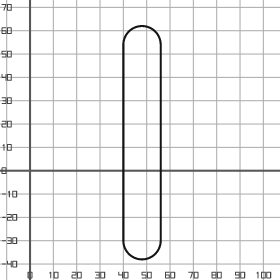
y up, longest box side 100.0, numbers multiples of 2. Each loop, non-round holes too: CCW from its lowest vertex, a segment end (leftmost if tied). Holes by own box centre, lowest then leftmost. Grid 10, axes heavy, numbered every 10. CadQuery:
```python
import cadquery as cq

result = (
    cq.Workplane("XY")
    .moveTo(40.0, -30.0)
    .threePointArc((48.0, -38.0), (56.0, -30.0))
    .lineTo(56.0, 54.0)
    .threePointArc((48.0, 62.0), (40.0, 54.0))
    .close()
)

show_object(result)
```